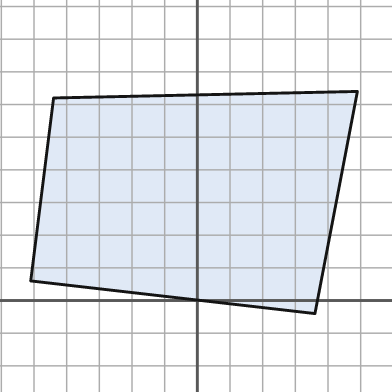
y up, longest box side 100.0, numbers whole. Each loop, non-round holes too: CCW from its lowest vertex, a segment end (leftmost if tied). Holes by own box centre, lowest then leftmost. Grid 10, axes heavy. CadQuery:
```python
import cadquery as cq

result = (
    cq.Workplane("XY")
    .moveTo(36.0, -4.0)
    .lineTo(49.0, 64.0)
    .lineTo(-44.0, 62.0)
    .lineTo(-51.0, 6.0)
    .close()
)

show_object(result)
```